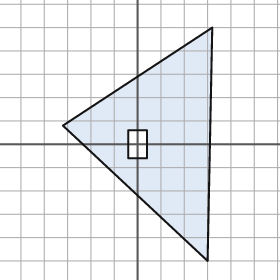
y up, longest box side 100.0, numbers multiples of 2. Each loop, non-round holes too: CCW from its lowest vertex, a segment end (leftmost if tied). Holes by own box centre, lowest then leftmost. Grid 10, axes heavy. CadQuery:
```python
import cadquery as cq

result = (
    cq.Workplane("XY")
    .moveTo(30.0, -50.0)
    .lineTo(32.0, 50.0)
    .lineTo(-32.0, 8.0)
    .close()
    .moveTo(-4.0, -6.0)
    .lineTo(4.0, -6.0)
    .lineTo(4.0, 6.0)
    .lineTo(-4.0, 6.0)
    .close()
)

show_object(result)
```